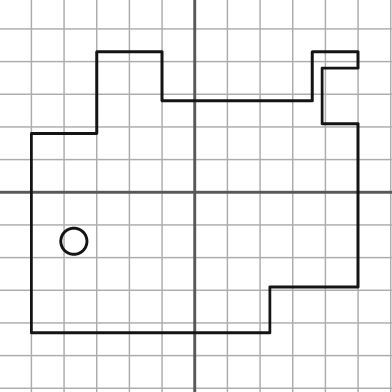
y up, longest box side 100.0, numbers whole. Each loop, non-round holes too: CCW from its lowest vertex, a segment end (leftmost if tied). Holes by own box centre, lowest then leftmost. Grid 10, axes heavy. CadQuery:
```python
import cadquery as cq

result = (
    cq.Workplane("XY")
    .moveTo(-50.0, -43.0)
    .lineTo(23.0, -43.0)
    .lineTo(23.0, -29.0)
    .lineTo(50.0, -29.0)
    .lineTo(50.0, 21.0)
    .lineTo(39.0, 21.0)
    .lineTo(39.0, 38.0)
    .lineTo(50.0, 38.0)
    .lineTo(50.0, 43.0)
    .lineTo(36.0, 43.0)
    .lineTo(36.0, 28.0)
    .lineTo(-10.0, 28.0)
    .lineTo(-10.0, 43.0)
    .lineTo(-30.0, 43.0)
    .lineTo(-30.0, 18.0)
    .lineTo(-50.0, 18.0)
    .close()
    .moveTo(-37.0, -15.0)
    .circle(4.0)
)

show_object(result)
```